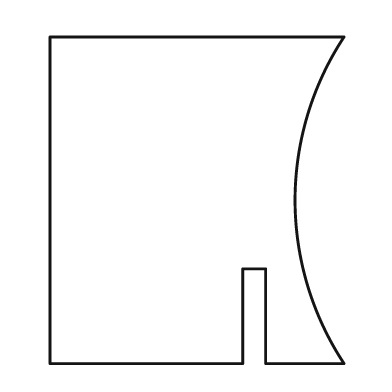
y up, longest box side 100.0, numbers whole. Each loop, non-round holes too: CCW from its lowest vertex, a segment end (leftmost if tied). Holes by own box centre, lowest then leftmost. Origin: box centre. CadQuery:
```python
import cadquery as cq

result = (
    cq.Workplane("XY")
    .moveTo(-45.0, -50.0)
    .lineTo(14.0, -50.0)
    .lineTo(14.0, -21.0)
    .lineTo(21.0, -21.0)
    .lineTo(21.0, -50.0)
    .lineTo(45.0, -50.0)
    .threePointArc((30.0, 0.0), (45.0, 50.0))
    .lineTo(-45.0, 50.0)
    .close()
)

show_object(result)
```